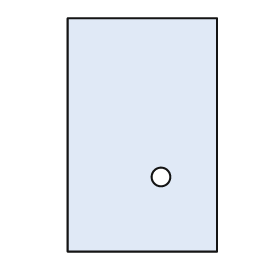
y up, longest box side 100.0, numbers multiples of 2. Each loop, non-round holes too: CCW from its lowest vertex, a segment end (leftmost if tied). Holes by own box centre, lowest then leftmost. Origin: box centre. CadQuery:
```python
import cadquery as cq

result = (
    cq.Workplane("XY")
    .moveTo(-32.0, -50.0)
    .lineTo(32.0, -50.0)
    .lineTo(32.0, 50.0)
    .lineTo(-32.0, 50.0)
    .close()
    .moveTo(8.0, -18.0)
    .circle(4.0)
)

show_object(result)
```